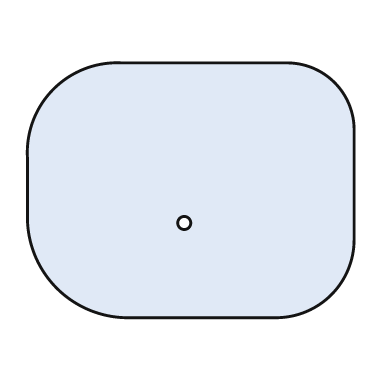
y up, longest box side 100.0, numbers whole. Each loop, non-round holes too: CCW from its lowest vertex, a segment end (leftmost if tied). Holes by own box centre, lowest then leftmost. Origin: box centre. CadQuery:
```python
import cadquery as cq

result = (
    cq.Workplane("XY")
    .moveTo(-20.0, -39.0)
    .lineTo(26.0, -39.0)
    .threePointArc((43.0, -32.0), (50.0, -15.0))
    .lineTo(50.0, 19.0)
    .threePointArc((44.0, 33.0), (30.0, 39.0))
    .lineTo(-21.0, 39.0)
    .threePointArc((-42.0, 31.0), (-50.0, 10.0))
    .lineTo(-50.0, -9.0)
    .threePointArc((-41.0, -30.0), (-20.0, -39.0))
    .close()
    .moveTo(-2.0, -10.0)
    .circle(2.0)
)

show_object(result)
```